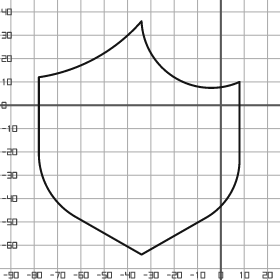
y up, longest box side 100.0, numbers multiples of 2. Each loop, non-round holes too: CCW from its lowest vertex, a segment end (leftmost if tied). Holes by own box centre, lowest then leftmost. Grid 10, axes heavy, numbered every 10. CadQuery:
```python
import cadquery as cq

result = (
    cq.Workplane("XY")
    .moveTo(-34.0, -64.0)
    .lineTo(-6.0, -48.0)
    .threePointArc((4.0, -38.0), (8.0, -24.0))
    .lineTo(8.0, 10.0)
    .threePointArc((-20.0, 12.0), (-34.0, 36.0))
    .threePointArc((-54.0, 20.0), (-78.0, 12.0))
    .lineTo(-78.0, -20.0)
    .threePointArc((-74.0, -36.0), (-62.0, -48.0))
    .close()
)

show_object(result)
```